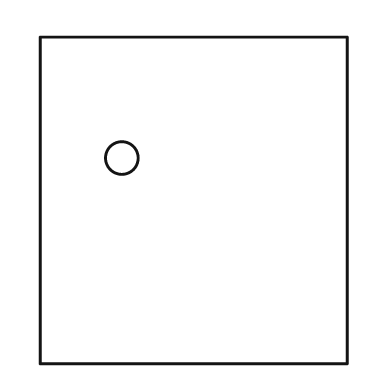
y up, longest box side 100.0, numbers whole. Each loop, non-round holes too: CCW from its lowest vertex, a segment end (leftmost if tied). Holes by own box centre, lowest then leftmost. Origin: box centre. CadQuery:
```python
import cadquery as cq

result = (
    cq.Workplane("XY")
    .moveTo(-47.0, -50.0)
    .lineTo(47.0, -50.0)
    .lineTo(47.0, 50.0)
    .lineTo(-47.0, 50.0)
    .close()
    .moveTo(-22.0, 13.0)
    .circle(5.0)
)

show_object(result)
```